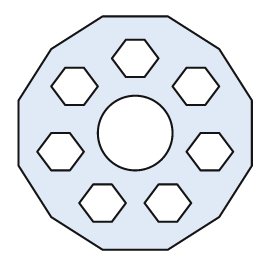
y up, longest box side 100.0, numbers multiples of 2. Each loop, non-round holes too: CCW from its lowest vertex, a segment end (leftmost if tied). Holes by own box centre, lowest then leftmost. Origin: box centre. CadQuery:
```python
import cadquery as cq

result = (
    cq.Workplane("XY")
    .moveTo(-14.0, -50.0)
    .lineTo(14.0, -50.0)
    .lineTo(36.0, -36.0)
    .lineTo(50.0, -14.0)
    .lineTo(50.0, 14.0)
    .lineTo(36.0, 36.0)
    .lineTo(14.0, 50.0)
    .lineTo(-14.0, 50.0)
    .lineTo(-36.0, 36.0)
    .lineTo(-50.0, 14.0)
    .lineTo(-50.0, -14.0)
    .lineTo(-36.0, -36.0)
    .close()
    .moveTo(-18.0, -38.0)
    .lineTo(-10.0, -38.0)
    .lineTo(-4.0, -30.0)
    .lineTo(-10.0, -22.0)
    .lineTo(-18.0, -22.0)
    .lineTo(-24.0, -30.0)
    .close()
    .moveTo(10.0, -38.0)
    .lineTo(18.0, -38.0)
    .lineTo(24.0, -30.0)
    .lineTo(18.0, -22.0)
    .lineTo(10.0, -22.0)
    .lineTo(4.0, -30.0)
    .close()
    .moveTo(-36.0, -16.0)
    .lineTo(-28.0, -16.0)
    .lineTo(-22.0, -8.0)
    .lineTo(-28.0, 0.0)
    .lineTo(-36.0, 0.0)
    .lineTo(-42.0, -8.0)
    .close()
    .moveTo(28.0, -16.0)
    .lineTo(36.0, -16.0)
    .lineTo(42.0, -8.0)
    .lineTo(36.0, 0.0)
    .lineTo(28.0, 0.0)
    .lineTo(22.0, -8.0)
    .close()
    .moveTo(0.0, 0.0)
    .circle(16.0)
    .moveTo(-30.0, 12.0)
    .lineTo(-22.0, 12.0)
    .lineTo(-16.0, 20.0)
    .lineTo(-22.0, 28.0)
    .lineTo(-30.0, 28.0)
    .lineTo(-36.0, 20.0)
    .close()
    .moveTo(22.0, 12.0)
    .lineTo(30.0, 12.0)
    .lineTo(36.0, 20.0)
    .lineTo(30.0, 28.0)
    .lineTo(22.0, 28.0)
    .lineTo(16.0, 20.0)
    .close()
    .moveTo(-4.0, 24.0)
    .lineTo(4.0, 24.0)
    .lineTo(10.0, 32.0)
    .lineTo(4.0, 40.0)
    .lineTo(-4.0, 40.0)
    .lineTo(-10.0, 32.0)
    .close()
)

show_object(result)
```